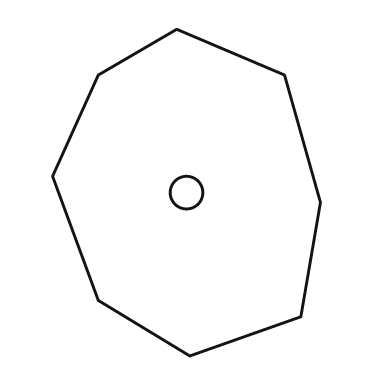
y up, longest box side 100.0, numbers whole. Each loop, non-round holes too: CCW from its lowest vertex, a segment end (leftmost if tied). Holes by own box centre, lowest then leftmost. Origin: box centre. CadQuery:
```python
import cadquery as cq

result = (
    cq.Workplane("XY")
    .moveTo(1.0, -50.0)
    .lineTo(35.0, -38.0)
    .lineTo(41.0, -3.0)
    .lineTo(30.0, 36.0)
    .lineTo(-3.0, 50.0)
    .lineTo(-27.0, 36.0)
    .lineTo(-41.0, 5.0)
    .lineTo(-27.0, -33.0)
    .close()
    .moveTo(0.0, 0.0)
    .circle(5.0)
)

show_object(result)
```